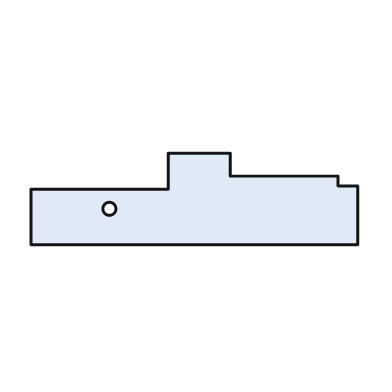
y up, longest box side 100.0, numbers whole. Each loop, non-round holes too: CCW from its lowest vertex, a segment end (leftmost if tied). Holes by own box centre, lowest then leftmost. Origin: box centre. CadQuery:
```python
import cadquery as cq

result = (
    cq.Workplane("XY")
    .moveTo(-50.0, -14.0)
    .lineTo(50.0, -14.0)
    .lineTo(50.0, 4.0)
    .lineTo(44.0, 4.0)
    .lineTo(44.0, 7.0)
    .lineTo(11.0, 7.0)
    .lineTo(11.0, 14.0)
    .lineTo(-8.0, 14.0)
    .lineTo(-8.0, 3.0)
    .lineTo(-50.0, 3.0)
    .close()
    .moveTo(-26.0, -3.0)
    .circle(2.0)
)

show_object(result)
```